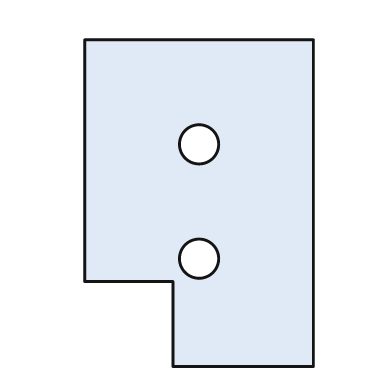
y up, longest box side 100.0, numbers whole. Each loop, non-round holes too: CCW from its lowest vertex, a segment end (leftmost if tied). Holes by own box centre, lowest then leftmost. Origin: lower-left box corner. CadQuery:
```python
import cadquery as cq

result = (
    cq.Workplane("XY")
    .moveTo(27.0, 0.0)
    .lineTo(70.0, 0.0)
    .lineTo(70.0, 100.0)
    .lineTo(0.0, 100.0)
    .lineTo(0.0, 26.0)
    .lineTo(27.0, 26.0)
    .close()
    .moveTo(35.0, 33.0)
    .circle(6.0)
    .moveTo(35.0, 68.0)
    .circle(6.0)
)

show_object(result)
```